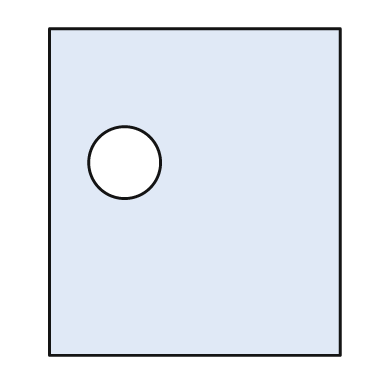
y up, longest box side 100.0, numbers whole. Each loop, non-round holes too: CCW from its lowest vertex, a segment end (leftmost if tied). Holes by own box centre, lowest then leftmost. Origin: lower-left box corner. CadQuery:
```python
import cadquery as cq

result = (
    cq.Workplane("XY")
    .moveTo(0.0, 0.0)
    .lineTo(89.0, 0.0)
    .lineTo(89.0, 100.0)
    .lineTo(0.0, 100.0)
    .close()
    .moveTo(23.0, 59.0)
    .circle(11.0)
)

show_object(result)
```